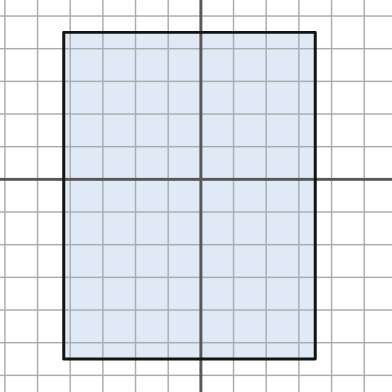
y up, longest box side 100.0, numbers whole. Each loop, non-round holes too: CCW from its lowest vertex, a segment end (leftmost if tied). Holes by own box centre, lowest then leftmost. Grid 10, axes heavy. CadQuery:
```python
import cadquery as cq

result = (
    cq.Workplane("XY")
    .moveTo(-42.0, -55.0)
    .lineTo(35.0, -55.0)
    .lineTo(35.0, 45.0)
    .lineTo(-42.0, 45.0)
    .close()
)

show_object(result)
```